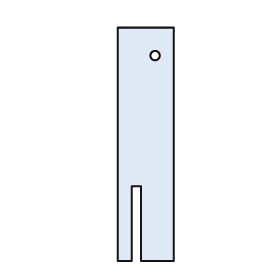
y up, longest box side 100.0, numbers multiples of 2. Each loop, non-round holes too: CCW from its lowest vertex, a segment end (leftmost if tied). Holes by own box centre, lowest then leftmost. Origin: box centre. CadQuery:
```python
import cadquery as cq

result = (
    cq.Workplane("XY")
    .moveTo(-12.0, -50.0)
    .lineTo(-6.0, -50.0)
    .lineTo(-6.0, -18.0)
    .lineTo(-2.0, -18.0)
    .lineTo(-2.0, -50.0)
    .lineTo(12.0, -50.0)
    .lineTo(12.0, 50.0)
    .lineTo(-12.0, 50.0)
    .close()
    .moveTo(4.0, 38.0)
    .circle(2.0)
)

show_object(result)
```